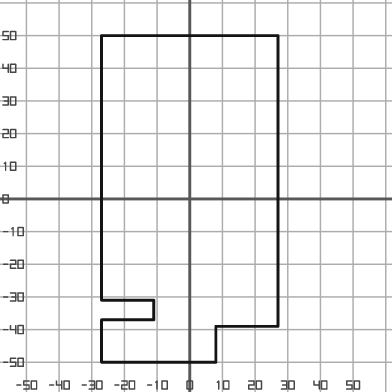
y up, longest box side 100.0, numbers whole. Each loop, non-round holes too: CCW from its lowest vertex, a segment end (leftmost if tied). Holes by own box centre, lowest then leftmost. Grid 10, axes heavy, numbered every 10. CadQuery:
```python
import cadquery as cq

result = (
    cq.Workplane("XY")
    .moveTo(-27.0, -50.0)
    .lineTo(8.0, -50.0)
    .lineTo(8.0, -39.0)
    .lineTo(27.0, -39.0)
    .lineTo(27.0, 50.0)
    .lineTo(-27.0, 50.0)
    .lineTo(-27.0, -31.0)
    .lineTo(-11.0, -31.0)
    .lineTo(-11.0, -37.0)
    .lineTo(-27.0, -37.0)
    .close()
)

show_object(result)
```